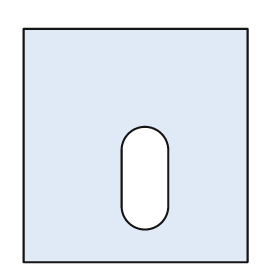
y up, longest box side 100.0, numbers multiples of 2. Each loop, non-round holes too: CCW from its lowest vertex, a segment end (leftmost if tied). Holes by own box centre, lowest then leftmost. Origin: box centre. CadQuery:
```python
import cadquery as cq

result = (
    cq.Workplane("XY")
    .moveTo(-48.0, -50.0)
    .lineTo(48.0, -50.0)
    .lineTo(48.0, 50.0)
    .lineTo(-48.0, 50.0)
    .close()
    .moveTo(-6.0, -26.0)
    .threePointArc((4.0, -36.0), (14.0, -26.0))
    .lineTo(14.0, -2.0)
    .threePointArc((4.0, 8.0), (-6.0, -2.0))
    .close()
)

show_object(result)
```